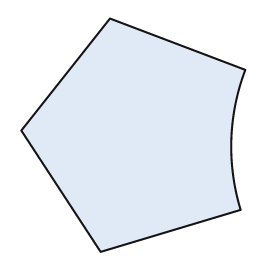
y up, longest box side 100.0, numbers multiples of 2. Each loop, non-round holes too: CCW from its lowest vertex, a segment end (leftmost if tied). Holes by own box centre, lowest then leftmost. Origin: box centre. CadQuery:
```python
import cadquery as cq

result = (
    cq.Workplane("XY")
    .moveTo(-14.0, -50.0)
    .lineTo(46.0, -32.0)
    .threePointArc((42.0, -2.0), (48.0, 28.0))
    .lineTo(-10.0, 50.0)
    .lineTo(-48.0, 2.0)
    .close()
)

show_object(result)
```